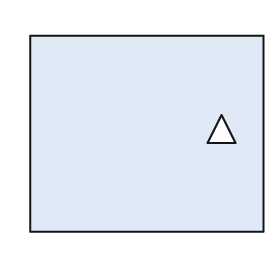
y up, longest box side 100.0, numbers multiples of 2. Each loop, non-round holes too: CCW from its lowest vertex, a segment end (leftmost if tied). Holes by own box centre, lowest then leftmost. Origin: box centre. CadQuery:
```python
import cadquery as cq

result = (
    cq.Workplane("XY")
    .moveTo(-50.0, -42.0)
    .lineTo(50.0, -42.0)
    .lineTo(50.0, 42.0)
    .lineTo(-50.0, 42.0)
    .close()
    .moveTo(26.0, -4.0)
    .lineTo(38.0, -4.0)
    .lineTo(32.0, 8.0)
    .close()
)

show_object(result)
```